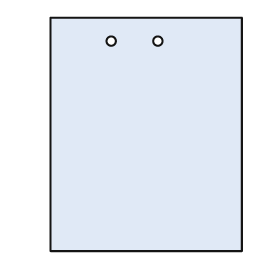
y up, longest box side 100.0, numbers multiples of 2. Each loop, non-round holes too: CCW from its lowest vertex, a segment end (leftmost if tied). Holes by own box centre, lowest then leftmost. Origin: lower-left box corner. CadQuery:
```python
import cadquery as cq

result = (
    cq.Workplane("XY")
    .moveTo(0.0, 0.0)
    .lineTo(82.0, 0.0)
    .lineTo(82.0, 100.0)
    .lineTo(0.0, 100.0)
    .close()
    .moveTo(26.0, 90.0)
    .circle(2.0)
    .moveTo(46.0, 90.0)
    .circle(2.0)
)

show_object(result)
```